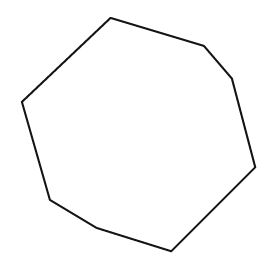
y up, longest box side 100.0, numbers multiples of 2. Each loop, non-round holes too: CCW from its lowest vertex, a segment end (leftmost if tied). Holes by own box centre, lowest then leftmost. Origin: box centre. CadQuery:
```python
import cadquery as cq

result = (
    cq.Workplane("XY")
    .moveTo(14.0, -50.0)
    .lineTo(50.0, -14.0)
    .lineTo(40.0, 24.0)
    .lineTo(28.0, 38.0)
    .lineTo(-12.0, 50.0)
    .lineTo(-50.0, 14.0)
    .lineTo(-38.0, -28.0)
    .lineTo(-18.0, -40.0)
    .close()
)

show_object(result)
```